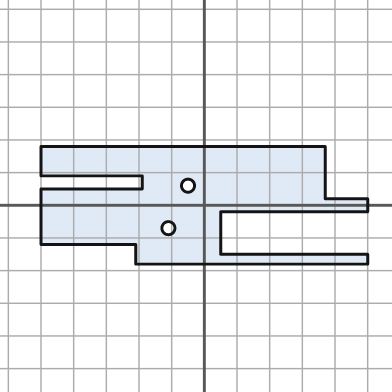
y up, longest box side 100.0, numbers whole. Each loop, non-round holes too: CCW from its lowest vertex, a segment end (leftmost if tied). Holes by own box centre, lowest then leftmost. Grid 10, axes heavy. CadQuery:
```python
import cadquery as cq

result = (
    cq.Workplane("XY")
    .moveTo(-21.0, -18.0)
    .lineTo(50.0, -18.0)
    .lineTo(50.0, -15.0)
    .lineTo(5.0, -15.0)
    .lineTo(5.0, -2.0)
    .lineTo(50.0, -2.0)
    .lineTo(50.0, 2.0)
    .lineTo(37.0, 2.0)
    .lineTo(37.0, 18.0)
    .lineTo(-50.0, 18.0)
    .lineTo(-50.0, 9.0)
    .lineTo(-19.0, 9.0)
    .lineTo(-19.0, 5.0)
    .lineTo(-50.0, 5.0)
    .lineTo(-50.0, -12.0)
    .lineTo(-21.0, -12.0)
    .close()
    .moveTo(-11.0, -7.0)
    .circle(2.0)
    .moveTo(-5.0, 6.0)
    .circle(2.0)
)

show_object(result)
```